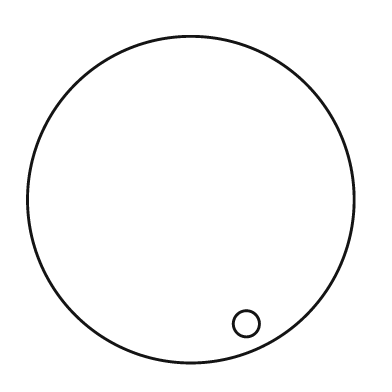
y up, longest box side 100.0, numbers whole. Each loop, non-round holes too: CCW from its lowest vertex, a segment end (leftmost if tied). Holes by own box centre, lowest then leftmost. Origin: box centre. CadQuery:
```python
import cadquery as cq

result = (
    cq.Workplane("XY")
    .moveTo(0.0, 0.0)
    .circle(50.0)
    .moveTo(17.0, -38.0)
    .circle(4.0)
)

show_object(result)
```